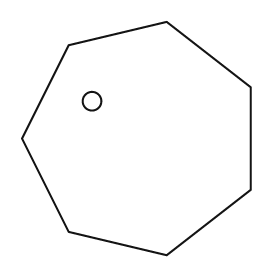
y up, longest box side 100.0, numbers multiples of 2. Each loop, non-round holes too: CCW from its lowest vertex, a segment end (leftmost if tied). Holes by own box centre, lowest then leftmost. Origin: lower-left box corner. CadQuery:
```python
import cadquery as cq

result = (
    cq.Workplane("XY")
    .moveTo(62.0, 0.0)
    .lineTo(98.0, 28.0)
    .lineTo(98.0, 72.0)
    .lineTo(62.0, 100.0)
    .lineTo(20.0, 90.0)
    .lineTo(0.0, 50.0)
    .lineTo(20.0, 10.0)
    .close()
    .moveTo(30.0, 66.0)
    .circle(4.0)
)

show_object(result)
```